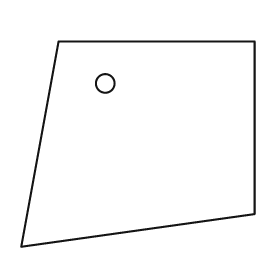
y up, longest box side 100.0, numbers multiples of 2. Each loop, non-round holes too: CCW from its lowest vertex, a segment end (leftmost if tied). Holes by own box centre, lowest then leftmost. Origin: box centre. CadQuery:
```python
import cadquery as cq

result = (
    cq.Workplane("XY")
    .moveTo(-50.0, -44.0)
    .lineTo(50.0, -30.0)
    .lineTo(50.0, 44.0)
    .lineTo(-34.0, 44.0)
    .close()
    .moveTo(-14.0, 26.0)
    .circle(4.0)
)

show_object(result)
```